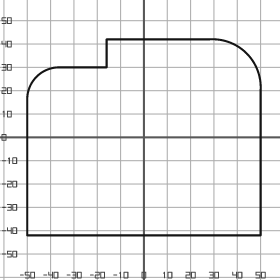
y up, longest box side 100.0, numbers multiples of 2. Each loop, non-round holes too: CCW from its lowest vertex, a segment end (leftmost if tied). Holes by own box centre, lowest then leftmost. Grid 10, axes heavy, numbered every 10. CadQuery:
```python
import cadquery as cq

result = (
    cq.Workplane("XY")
    .moveTo(-50.0, -42.0)
    .lineTo(50.0, -42.0)
    .lineTo(50.0, 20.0)
    .threePointArc((44.0, 36.0), (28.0, 42.0))
    .lineTo(-16.0, 42.0)
    .lineTo(-16.0, 30.0)
    .lineTo(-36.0, 30.0)
    .threePointArc((-46.0, 26.0), (-50.0, 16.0))
    .close()
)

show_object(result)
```